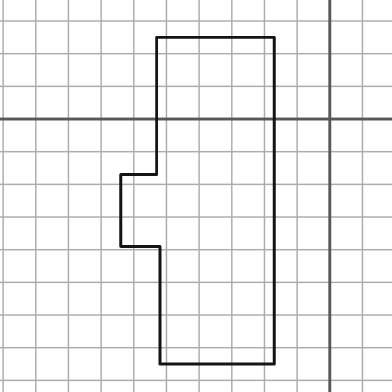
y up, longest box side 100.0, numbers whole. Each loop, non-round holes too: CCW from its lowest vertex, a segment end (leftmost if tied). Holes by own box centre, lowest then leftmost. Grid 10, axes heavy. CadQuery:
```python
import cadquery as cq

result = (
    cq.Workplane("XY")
    .moveTo(-52.0, -75.0)
    .lineTo(-17.0, -75.0)
    .lineTo(-17.0, 25.0)
    .lineTo(-53.0, 25.0)
    .lineTo(-53.0, -17.0)
    .lineTo(-64.0, -17.0)
    .lineTo(-64.0, -39.0)
    .lineTo(-52.0, -39.0)
    .close()
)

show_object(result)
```